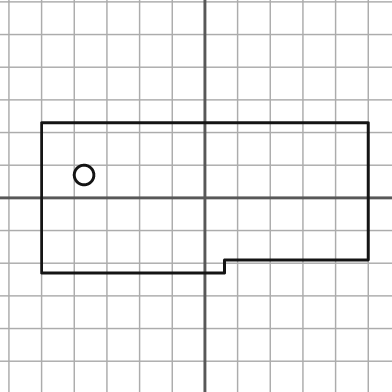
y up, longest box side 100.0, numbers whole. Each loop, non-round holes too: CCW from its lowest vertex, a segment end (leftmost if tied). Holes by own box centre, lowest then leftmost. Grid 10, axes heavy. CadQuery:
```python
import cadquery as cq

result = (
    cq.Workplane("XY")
    .moveTo(-50.0, -23.0)
    .lineTo(6.0, -23.0)
    .lineTo(6.0, -19.0)
    .lineTo(50.0, -19.0)
    .lineTo(50.0, 23.0)
    .lineTo(-50.0, 23.0)
    .close()
    .moveTo(-37.0, 7.0)
    .circle(3.0)
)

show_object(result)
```